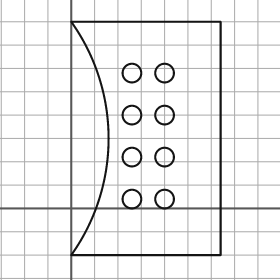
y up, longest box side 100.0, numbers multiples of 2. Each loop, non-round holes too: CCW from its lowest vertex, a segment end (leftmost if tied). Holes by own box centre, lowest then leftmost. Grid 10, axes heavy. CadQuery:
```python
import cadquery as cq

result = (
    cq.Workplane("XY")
    .moveTo(0.0, -20.0)
    .lineTo(64.0, -20.0)
    .lineTo(64.0, 80.0)
    .lineTo(0.0, 80.0)
    .threePointArc((16.0, 30.0), (0.0, -20.0))
    .close()
    .moveTo(26.0, 4.0)
    .circle(4.0)
    .moveTo(40.0, 4.0)
    .circle(4.0)
    .moveTo(26.0, 22.0)
    .circle(4.0)
    .moveTo(40.0, 22.0)
    .circle(4.0)
    .moveTo(26.0, 40.0)
    .circle(4.0)
    .moveTo(40.0, 40.0)
    .circle(4.0)
    .moveTo(26.0, 58.0)
    .circle(4.0)
    .moveTo(40.0, 58.0)
    .circle(4.0)
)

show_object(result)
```